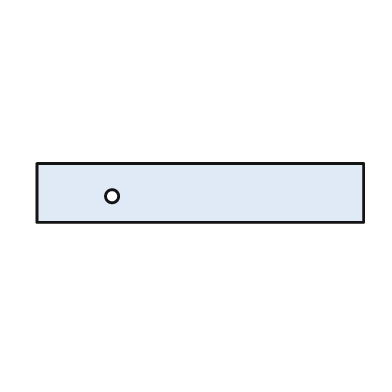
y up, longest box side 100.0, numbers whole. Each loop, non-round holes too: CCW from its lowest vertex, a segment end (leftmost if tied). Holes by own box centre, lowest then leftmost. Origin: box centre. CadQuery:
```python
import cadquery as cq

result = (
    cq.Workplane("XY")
    .moveTo(-50.0, -9.0)
    .lineTo(50.0, -9.0)
    .lineTo(50.0, 9.0)
    .lineTo(-50.0, 9.0)
    .close()
    .moveTo(-27.0, -1.0)
    .circle(2.0)
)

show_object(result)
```